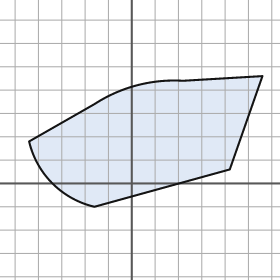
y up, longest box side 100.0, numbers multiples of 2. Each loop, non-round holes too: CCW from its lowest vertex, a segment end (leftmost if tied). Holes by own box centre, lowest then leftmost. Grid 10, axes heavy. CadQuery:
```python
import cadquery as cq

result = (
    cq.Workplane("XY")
    .moveTo(-16.0, -10.0)
    .lineTo(42.0, 6.0)
    .lineTo(56.0, 46.0)
    .lineTo(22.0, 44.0)
    .threePointArc((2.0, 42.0), (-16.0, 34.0))
    .lineTo(-44.0, 18.0)
    .threePointArc((-34.0, 0.0), (-16.0, -10.0))
    .close()
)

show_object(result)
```